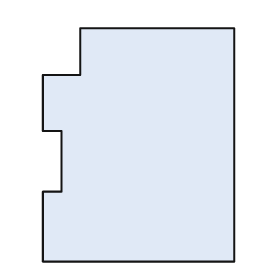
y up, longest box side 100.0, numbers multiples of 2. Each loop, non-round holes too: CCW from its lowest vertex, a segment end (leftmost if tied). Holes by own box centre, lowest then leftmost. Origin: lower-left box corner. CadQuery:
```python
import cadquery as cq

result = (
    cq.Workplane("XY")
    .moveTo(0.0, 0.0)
    .lineTo(82.0, 0.0)
    .lineTo(82.0, 100.0)
    .lineTo(16.0, 100.0)
    .lineTo(16.0, 80.0)
    .lineTo(0.0, 80.0)
    .lineTo(0.0, 56.0)
    .lineTo(8.0, 56.0)
    .lineTo(8.0, 30.0)
    .lineTo(0.0, 30.0)
    .close()
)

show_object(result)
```